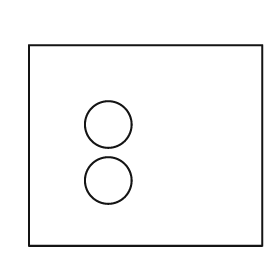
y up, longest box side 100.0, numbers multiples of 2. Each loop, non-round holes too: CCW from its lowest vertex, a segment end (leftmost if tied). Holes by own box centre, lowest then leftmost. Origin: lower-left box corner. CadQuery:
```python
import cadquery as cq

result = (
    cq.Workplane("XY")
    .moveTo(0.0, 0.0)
    .lineTo(100.0, 0.0)
    .lineTo(100.0, 86.0)
    .lineTo(0.0, 86.0)
    .close()
    .moveTo(34.0, 28.0)
    .circle(10.0)
    .moveTo(34.0, 52.0)
    .circle(10.0)
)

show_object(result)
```